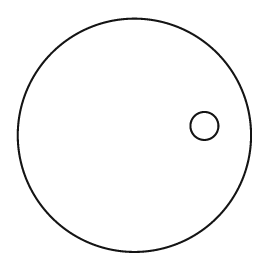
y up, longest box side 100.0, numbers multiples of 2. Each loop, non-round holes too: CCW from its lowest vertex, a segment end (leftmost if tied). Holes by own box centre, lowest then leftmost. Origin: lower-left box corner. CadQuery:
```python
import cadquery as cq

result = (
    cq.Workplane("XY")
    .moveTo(50.0, 50.0)
    .circle(50.0)
    .moveTo(80.0, 54.0)
    .circle(6.0)
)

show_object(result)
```